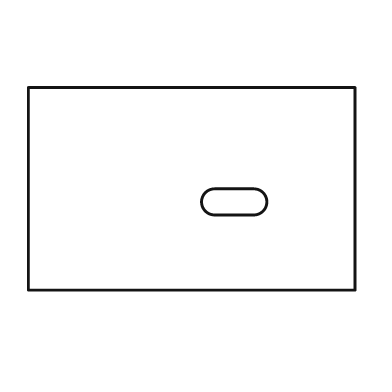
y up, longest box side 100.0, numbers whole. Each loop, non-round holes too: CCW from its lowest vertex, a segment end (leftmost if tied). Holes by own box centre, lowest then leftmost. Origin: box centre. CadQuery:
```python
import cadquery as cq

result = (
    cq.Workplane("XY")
    .moveTo(-50.0, -31.0)
    .lineTo(50.0, -31.0)
    .lineTo(50.0, 31.0)
    .lineTo(-50.0, 31.0)
    .close()
    .moveTo(7.0, -8.0)
    .lineTo(19.0, -8.0)
    .threePointArc((23.0, -4.0), (19.0, 0.0))
    .lineTo(7.0, 0.0)
    .threePointArc((3.0, -4.0), (7.0, -8.0))
    .close()
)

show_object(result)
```